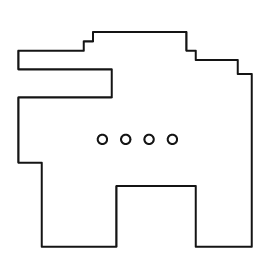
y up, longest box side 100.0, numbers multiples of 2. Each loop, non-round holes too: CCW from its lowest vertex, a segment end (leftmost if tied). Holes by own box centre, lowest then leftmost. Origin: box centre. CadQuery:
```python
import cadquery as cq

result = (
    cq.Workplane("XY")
    .moveTo(-40.0, -46.0)
    .lineTo(-8.0, -46.0)
    .lineTo(-8.0, -20.0)
    .lineTo(26.0, -20.0)
    .lineTo(26.0, -46.0)
    .lineTo(50.0, -46.0)
    .lineTo(50.0, 28.0)
    .lineTo(44.0, 28.0)
    .lineTo(44.0, 34.0)
    .lineTo(26.0, 34.0)
    .lineTo(26.0, 38.0)
    .lineTo(22.0, 38.0)
    .lineTo(22.0, 46.0)
    .lineTo(-18.0, 46.0)
    .lineTo(-18.0, 42.0)
    .lineTo(-22.0, 42.0)
    .lineTo(-22.0, 38.0)
    .lineTo(-50.0, 38.0)
    .lineTo(-50.0, 30.0)
    .lineTo(-10.0, 30.0)
    .lineTo(-10.0, 18.0)
    .lineTo(-50.0, 18.0)
    .lineTo(-50.0, -10.0)
    .lineTo(-40.0, -10.0)
    .close()
    .moveTo(-14.0, 0.0)
    .circle(2.0)
    .moveTo(-4.0, 0.0)
    .circle(2.0)
    .moveTo(6.0, 0.0)
    .circle(2.0)
    .moveTo(16.0, 0.0)
    .circle(2.0)
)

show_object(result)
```